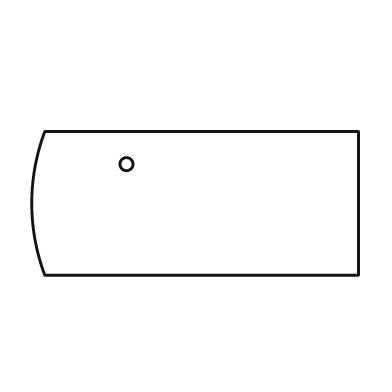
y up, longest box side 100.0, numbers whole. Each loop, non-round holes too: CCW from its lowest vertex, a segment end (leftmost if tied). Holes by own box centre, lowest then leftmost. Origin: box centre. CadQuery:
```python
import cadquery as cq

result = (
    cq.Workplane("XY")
    .moveTo(-46.0, -22.0)
    .lineTo(50.0, -22.0)
    .lineTo(50.0, 22.0)
    .lineTo(-46.0, 22.0)
    .threePointArc((-50.0, 0.0), (-46.0, -22.0))
    .close()
    .moveTo(-21.0, 12.0)
    .circle(2.0)
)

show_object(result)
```